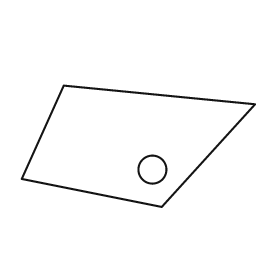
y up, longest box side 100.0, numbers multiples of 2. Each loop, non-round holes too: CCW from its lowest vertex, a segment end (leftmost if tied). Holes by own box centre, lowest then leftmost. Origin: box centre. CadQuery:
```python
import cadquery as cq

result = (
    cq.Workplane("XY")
    .moveTo(10.0, -26.0)
    .lineTo(50.0, 18.0)
    .lineTo(-32.0, 26.0)
    .lineTo(-50.0, -14.0)
    .close()
    .moveTo(6.0, -10.0)
    .circle(6.0)
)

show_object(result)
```